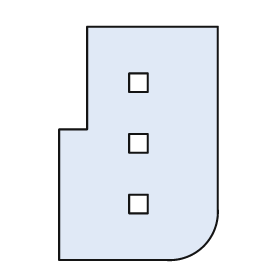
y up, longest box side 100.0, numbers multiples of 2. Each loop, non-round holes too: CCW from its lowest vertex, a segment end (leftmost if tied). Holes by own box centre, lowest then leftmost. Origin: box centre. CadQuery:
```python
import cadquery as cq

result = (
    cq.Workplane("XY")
    .moveTo(-34.0, -50.0)
    .lineTo(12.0, -50.0)
    .threePointArc((28.0, -44.0), (34.0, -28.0))
    .lineTo(34.0, 50.0)
    .lineTo(-22.0, 50.0)
    .lineTo(-22.0, 6.0)
    .lineTo(-34.0, 6.0)
    .close()
    .moveTo(-4.0, -30.0)
    .lineTo(4.0, -30.0)
    .lineTo(4.0, -22.0)
    .lineTo(-4.0, -22.0)
    .close()
    .moveTo(-4.0, -4.0)
    .lineTo(4.0, -4.0)
    .lineTo(4.0, 4.0)
    .lineTo(-4.0, 4.0)
    .close()
    .moveTo(-4.0, 22.0)
    .lineTo(4.0, 22.0)
    .lineTo(4.0, 30.0)
    .lineTo(-4.0, 30.0)
    .close()
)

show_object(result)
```